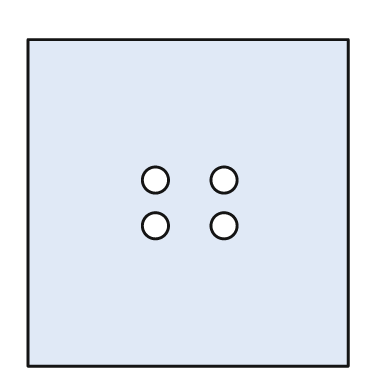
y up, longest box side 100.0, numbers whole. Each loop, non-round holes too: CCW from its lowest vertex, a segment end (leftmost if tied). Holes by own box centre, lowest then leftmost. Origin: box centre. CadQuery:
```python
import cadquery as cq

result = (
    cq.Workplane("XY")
    .moveTo(-49.0, -50.0)
    .lineTo(49.0, -50.0)
    .lineTo(49.0, 50.0)
    .lineTo(-49.0, 50.0)
    .close()
    .moveTo(-10.0, -7.0)
    .circle(4.0)
    .moveTo(11.0, -7.0)
    .circle(4.0)
    .moveTo(-10.0, 7.0)
    .circle(4.0)
    .moveTo(11.0, 7.0)
    .circle(4.0)
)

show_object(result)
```